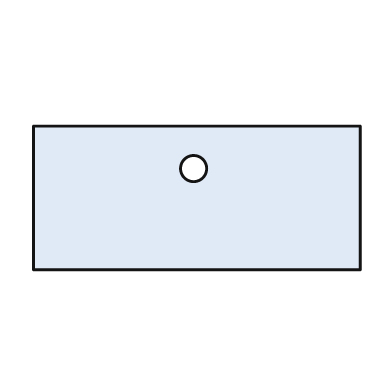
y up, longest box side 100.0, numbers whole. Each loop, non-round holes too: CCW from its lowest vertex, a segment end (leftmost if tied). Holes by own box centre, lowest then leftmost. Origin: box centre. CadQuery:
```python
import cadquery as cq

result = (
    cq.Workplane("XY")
    .moveTo(-50.0, -22.0)
    .lineTo(50.0, -22.0)
    .lineTo(50.0, 22.0)
    .lineTo(-50.0, 22.0)
    .close()
    .moveTo(-1.0, 9.0)
    .circle(4.0)
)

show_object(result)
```